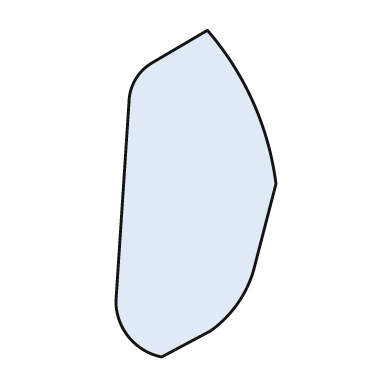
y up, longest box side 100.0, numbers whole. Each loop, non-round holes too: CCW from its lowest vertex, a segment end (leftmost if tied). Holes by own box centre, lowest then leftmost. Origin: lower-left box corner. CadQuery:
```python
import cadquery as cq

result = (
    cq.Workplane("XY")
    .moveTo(14.0, 0.0)
    .lineTo(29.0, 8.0)
    .threePointArc((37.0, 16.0), (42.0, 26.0))
    .lineTo(49.0, 53.0)
    .threePointArc((42.0, 78.0), (28.0, 100.0))
    .lineTo(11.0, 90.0)
    .threePointArc((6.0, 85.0), (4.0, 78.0))
    .lineTo(0.0, 17.0)
    .threePointArc((4.0, 6.0), (14.0, 0.0))
    .close()
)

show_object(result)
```